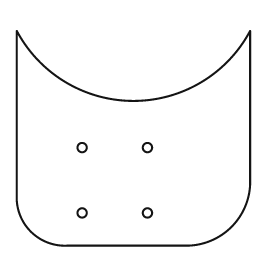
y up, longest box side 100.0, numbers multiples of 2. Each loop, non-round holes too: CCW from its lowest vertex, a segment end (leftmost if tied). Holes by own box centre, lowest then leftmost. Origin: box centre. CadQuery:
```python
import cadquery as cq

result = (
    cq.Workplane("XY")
    .moveTo(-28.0, -46.0)
    .lineTo(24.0, -46.0)
    .threePointArc((42.0, -38.0), (50.0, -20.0))
    .lineTo(50.0, 46.0)
    .threePointArc((0.0, 16.0), (-50.0, 46.0))
    .lineTo(-50.0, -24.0)
    .threePointArc((-44.0, -40.0), (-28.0, -46.0))
    .close()
    .moveTo(-22.0, -32.0)
    .circle(2.0)
    .moveTo(6.0, -32.0)
    .circle(2.0)
    .moveTo(-22.0, -4.0)
    .circle(2.0)
    .moveTo(6.0, -4.0)
    .circle(2.0)
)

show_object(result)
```